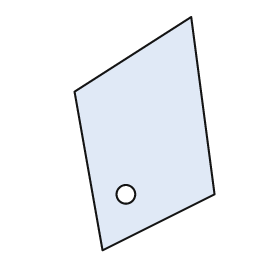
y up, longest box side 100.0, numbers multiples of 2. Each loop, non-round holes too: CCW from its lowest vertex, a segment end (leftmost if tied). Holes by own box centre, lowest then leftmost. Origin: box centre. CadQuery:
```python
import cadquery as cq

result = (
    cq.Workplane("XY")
    .moveTo(-18.0, -50.0)
    .lineTo(30.0, -26.0)
    .lineTo(20.0, 50.0)
    .lineTo(-30.0, 18.0)
    .close()
    .moveTo(-8.0, -26.0)
    .circle(4.0)
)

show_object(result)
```